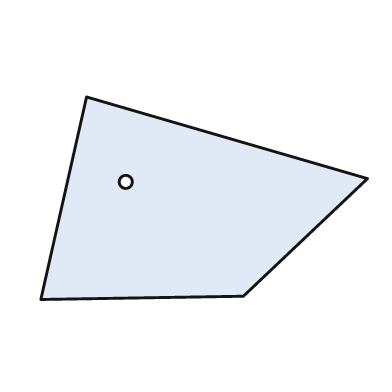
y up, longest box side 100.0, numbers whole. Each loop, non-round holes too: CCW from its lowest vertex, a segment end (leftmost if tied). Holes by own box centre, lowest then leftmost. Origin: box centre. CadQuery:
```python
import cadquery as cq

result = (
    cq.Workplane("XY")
    .moveTo(-50.0, -31.0)
    .lineTo(12.0, -30.0)
    .lineTo(50.0, 6.0)
    .lineTo(-36.0, 31.0)
    .close()
    .moveTo(-24.0, 5.0)
    .circle(2.0)
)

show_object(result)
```